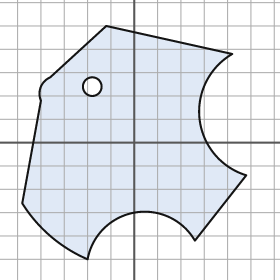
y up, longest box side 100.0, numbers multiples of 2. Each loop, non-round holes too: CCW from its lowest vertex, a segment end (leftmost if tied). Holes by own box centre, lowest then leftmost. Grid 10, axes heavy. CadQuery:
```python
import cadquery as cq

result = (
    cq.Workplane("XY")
    .moveTo(-20.0, -50.0)
    .threePointArc((0.0, -30.0), (26.0, -42.0))
    .lineTo(48.0, -14.0)
    .threePointArc((28.0, 10.0), (42.0, 38.0))
    .lineTo(-12.0, 50.0)
    .lineTo(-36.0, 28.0)
    .threePointArc((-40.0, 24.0), (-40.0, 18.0))
    .lineTo(-48.0, -26.0)
    .threePointArc((-36.0, -40.0), (-20.0, -50.0))
    .close()
    .moveTo(-18.0, 24.0)
    .circle(4.0)
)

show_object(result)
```